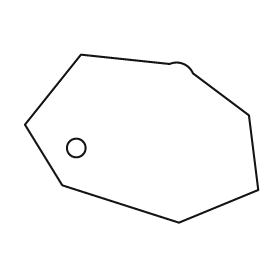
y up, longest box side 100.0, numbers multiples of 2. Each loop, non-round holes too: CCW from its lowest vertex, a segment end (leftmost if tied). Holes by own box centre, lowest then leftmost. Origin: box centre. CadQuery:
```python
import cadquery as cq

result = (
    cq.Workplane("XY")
    .moveTo(16.0, -36.0)
    .lineTo(50.0, -22.0)
    .lineTo(46.0, 10.0)
    .lineTo(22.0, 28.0)
    .threePointArc((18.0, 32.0), (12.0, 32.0))
    .lineTo(-26.0, 36.0)
    .lineTo(-50.0, 6.0)
    .lineTo(-34.0, -20.0)
    .close()
    .moveTo(-28.0, -4.0)
    .circle(4.0)
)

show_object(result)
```